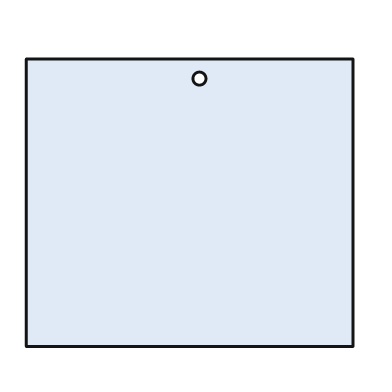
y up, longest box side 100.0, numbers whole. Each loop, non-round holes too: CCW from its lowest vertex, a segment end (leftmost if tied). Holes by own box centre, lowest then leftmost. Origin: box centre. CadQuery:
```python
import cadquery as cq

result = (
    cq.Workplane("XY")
    .moveTo(-50.0, -44.0)
    .lineTo(50.0, -44.0)
    .lineTo(50.0, 44.0)
    .lineTo(-50.0, 44.0)
    .close()
    .moveTo(3.0, 38.0)
    .circle(2.0)
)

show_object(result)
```